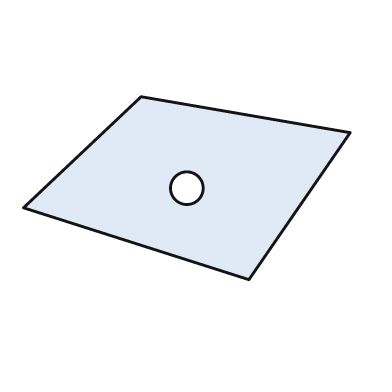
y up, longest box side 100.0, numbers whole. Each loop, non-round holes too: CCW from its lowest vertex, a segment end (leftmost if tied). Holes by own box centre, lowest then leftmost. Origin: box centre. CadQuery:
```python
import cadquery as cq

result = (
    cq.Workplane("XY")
    .moveTo(19.0, -28.0)
    .lineTo(50.0, 17.0)
    .lineTo(-14.0, 28.0)
    .lineTo(-50.0, -6.0)
    .close()
    .moveTo(0.0, 0.0)
    .circle(5.0)
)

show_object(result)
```